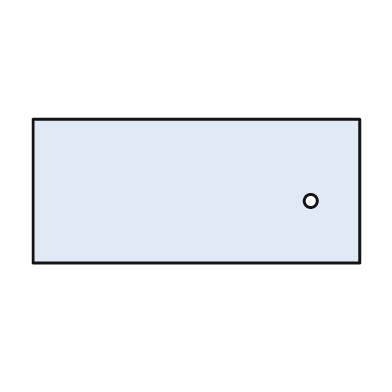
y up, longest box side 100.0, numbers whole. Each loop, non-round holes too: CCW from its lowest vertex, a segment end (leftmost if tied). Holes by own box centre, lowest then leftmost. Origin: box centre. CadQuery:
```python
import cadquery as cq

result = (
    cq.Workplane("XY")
    .moveTo(-50.0, -22.0)
    .lineTo(50.0, -22.0)
    .lineTo(50.0, 22.0)
    .lineTo(-50.0, 22.0)
    .close()
    .moveTo(35.0, -3.0)
    .circle(2.0)
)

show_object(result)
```